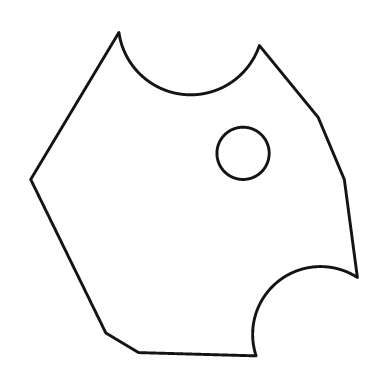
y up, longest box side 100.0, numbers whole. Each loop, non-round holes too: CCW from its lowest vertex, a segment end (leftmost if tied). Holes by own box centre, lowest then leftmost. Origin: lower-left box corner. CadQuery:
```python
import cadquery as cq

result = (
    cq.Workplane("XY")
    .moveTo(69.0, 0.0)
    .threePointArc((76.0, 23.0), (100.0, 24.0))
    .lineTo(96.0, 54.0)
    .lineTo(88.0, 73.0)
    .lineTo(70.0, 95.0)
    .threePointArc((47.0, 80.0), (27.0, 99.0))
    .lineTo(0.0, 54.0)
    .lineTo(23.0, 7.0)
    .lineTo(33.0, 1.0)
    .close()
    .moveTo(65.0, 62.0)
    .circle(8.0)
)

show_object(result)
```